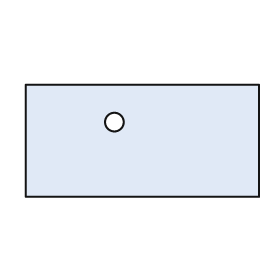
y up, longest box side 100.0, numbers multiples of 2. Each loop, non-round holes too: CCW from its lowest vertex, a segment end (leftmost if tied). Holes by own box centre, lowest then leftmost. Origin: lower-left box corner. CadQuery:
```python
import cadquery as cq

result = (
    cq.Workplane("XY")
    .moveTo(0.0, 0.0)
    .lineTo(100.0, 0.0)
    .lineTo(100.0, 48.0)
    .lineTo(0.0, 48.0)
    .close()
    .moveTo(38.0, 32.0)
    .circle(4.0)
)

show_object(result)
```